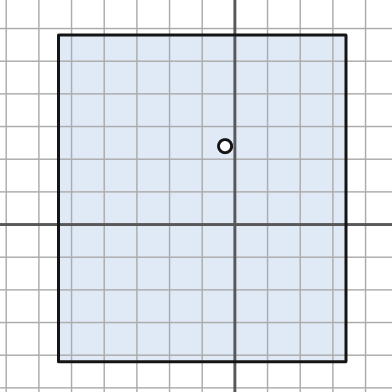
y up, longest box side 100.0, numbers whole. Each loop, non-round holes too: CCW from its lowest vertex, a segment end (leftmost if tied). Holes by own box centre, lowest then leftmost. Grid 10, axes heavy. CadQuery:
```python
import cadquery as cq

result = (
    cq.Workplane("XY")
    .moveTo(-54.0, -42.0)
    .lineTo(34.0, -42.0)
    .lineTo(34.0, 58.0)
    .lineTo(-54.0, 58.0)
    .close()
    .moveTo(-3.0, 24.0)
    .circle(2.0)
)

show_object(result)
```